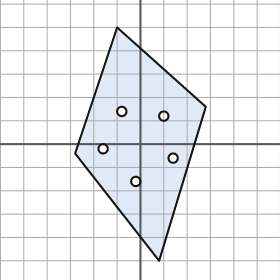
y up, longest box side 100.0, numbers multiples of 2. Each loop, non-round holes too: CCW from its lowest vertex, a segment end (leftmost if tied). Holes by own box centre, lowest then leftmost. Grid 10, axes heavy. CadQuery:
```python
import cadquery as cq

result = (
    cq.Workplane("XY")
    .moveTo(8.0, -50.0)
    .lineTo(28.0, 16.0)
    .lineTo(-10.0, 50.0)
    .lineTo(-28.0, -4.0)
    .close()
    .moveTo(-2.0, -16.0)
    .circle(2.0)
    .moveTo(14.0, -6.0)
    .circle(2.0)
    .moveTo(-16.0, -2.0)
    .circle(2.0)
    .moveTo(10.0, 12.0)
    .circle(2.0)
    .moveTo(-8.0, 14.0)
    .circle(2.0)
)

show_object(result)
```